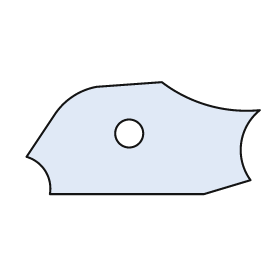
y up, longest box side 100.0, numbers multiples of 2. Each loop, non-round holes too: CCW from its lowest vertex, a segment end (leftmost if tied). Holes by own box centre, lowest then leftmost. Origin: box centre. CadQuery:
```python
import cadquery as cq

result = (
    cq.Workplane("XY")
    .moveTo(-40.0, -24.0)
    .lineTo(26.0, -24.0)
    .lineTo(46.0, -18.0)
    .threePointArc((42.0, -2.0), (50.0, 12.0))
    .threePointArc((28.0, 14.0), (8.0, 24.0))
    .lineTo(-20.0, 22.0)
    .threePointArc((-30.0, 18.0), (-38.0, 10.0))
    .lineTo(-50.0, -8.0)
    .threePointArc((-42.0, -14.0), (-40.0, -24.0))
    .close()
    .moveTo(-6.0, 2.0)
    .circle(6.0)
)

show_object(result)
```